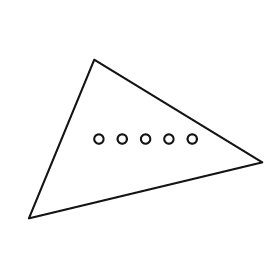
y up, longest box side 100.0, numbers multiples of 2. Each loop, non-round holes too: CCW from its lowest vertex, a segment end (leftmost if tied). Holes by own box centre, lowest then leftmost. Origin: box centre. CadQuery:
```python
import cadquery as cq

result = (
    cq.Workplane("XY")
    .moveTo(-50.0, -34.0)
    .lineTo(50.0, -10.0)
    .lineTo(-22.0, 34.0)
    .close()
    .moveTo(-20.0, 0.0)
    .circle(2.0)
    .moveTo(-10.0, 0.0)
    .circle(2.0)
    .moveTo(0.0, 0.0)
    .circle(2.0)
    .moveTo(10.0, 0.0)
    .circle(2.0)
    .moveTo(20.0, 0.0)
    .circle(2.0)
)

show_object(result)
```